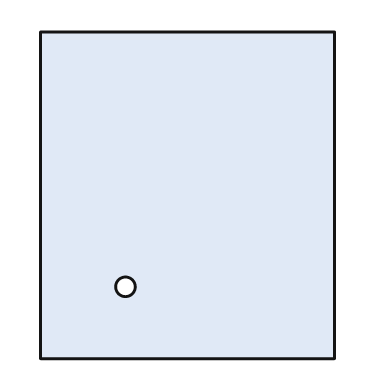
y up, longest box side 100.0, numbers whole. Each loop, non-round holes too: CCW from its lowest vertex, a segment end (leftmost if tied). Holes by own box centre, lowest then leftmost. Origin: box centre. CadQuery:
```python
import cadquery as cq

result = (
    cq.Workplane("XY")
    .moveTo(-45.0, -50.0)
    .lineTo(45.0, -50.0)
    .lineTo(45.0, 50.0)
    .lineTo(-45.0, 50.0)
    .close()
    .moveTo(-19.0, -28.0)
    .circle(3.0)
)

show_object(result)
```